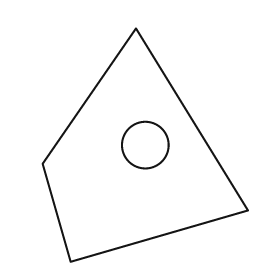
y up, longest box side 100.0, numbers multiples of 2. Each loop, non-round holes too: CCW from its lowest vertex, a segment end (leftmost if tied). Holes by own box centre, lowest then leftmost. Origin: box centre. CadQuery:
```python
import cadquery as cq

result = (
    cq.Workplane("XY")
    .moveTo(-32.0, -50.0)
    .lineTo(44.0, -28.0)
    .lineTo(-4.0, 50.0)
    .lineTo(-44.0, -8.0)
    .close()
    .moveTo(0.0, 0.0)
    .circle(10.0)
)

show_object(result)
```